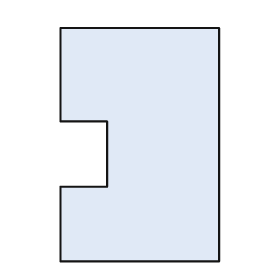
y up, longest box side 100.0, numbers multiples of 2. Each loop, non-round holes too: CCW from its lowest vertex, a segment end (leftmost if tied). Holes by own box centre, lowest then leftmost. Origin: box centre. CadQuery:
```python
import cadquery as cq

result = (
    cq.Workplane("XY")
    .moveTo(-34.0, -50.0)
    .lineTo(34.0, -50.0)
    .lineTo(34.0, 50.0)
    .lineTo(-34.0, 50.0)
    .lineTo(-34.0, 10.0)
    .lineTo(-14.0, 10.0)
    .lineTo(-14.0, -18.0)
    .lineTo(-34.0, -18.0)
    .close()
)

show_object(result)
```